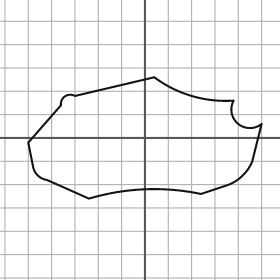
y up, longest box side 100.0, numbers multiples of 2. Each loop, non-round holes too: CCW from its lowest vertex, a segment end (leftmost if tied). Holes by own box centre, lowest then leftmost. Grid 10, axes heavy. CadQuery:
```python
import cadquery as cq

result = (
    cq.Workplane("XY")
    .moveTo(-24.0, -26.0)
    .threePointArc((0.0, -22.0), (24.0, -24.0))
    .lineTo(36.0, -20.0)
    .threePointArc((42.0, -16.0), (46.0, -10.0))
    .lineTo(50.0, 6.0)
    .threePointArc((40.0, 6.0), (38.0, 16.0))
    .threePointArc((20.0, 18.0), (4.0, 26.0))
    .lineTo(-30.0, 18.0)
    .threePointArc((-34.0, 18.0), (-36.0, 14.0))
    .lineTo(-50.0, -2.0)
    .lineTo(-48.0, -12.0)
    .threePointArc((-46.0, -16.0), (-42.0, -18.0))
    .close()
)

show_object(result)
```